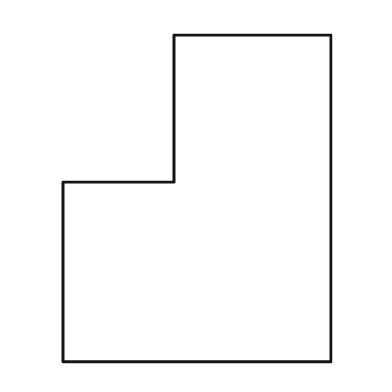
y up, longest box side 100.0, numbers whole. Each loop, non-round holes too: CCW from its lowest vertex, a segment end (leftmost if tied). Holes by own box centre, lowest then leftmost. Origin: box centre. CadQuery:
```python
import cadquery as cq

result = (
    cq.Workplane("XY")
    .moveTo(-41.0, -50.0)
    .lineTo(41.0, -50.0)
    .lineTo(41.0, 50.0)
    .lineTo(-7.0, 50.0)
    .lineTo(-7.0, 5.0)
    .lineTo(-41.0, 5.0)
    .close()
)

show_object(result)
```